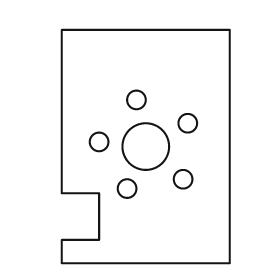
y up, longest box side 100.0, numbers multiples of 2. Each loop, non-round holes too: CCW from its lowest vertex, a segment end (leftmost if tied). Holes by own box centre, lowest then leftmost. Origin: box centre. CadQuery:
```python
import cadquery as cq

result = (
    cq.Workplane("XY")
    .moveTo(-36.0, -50.0)
    .lineTo(36.0, -50.0)
    .lineTo(36.0, 50.0)
    .lineTo(-36.0, 50.0)
    .lineTo(-36.0, -20.0)
    .lineTo(-20.0, -20.0)
    .lineTo(-20.0, -40.0)
    .lineTo(-36.0, -40.0)
    .close()
    .moveTo(-8.0, -18.0)
    .circle(4.0)
    .moveTo(16.0, -14.0)
    .circle(4.0)
    .moveTo(0.0, 0.0)
    .circle(10.0)
    .moveTo(-20.0, 2.0)
    .circle(4.0)
    .moveTo(18.0, 10.0)
    .circle(4.0)
    .moveTo(-4.0, 20.0)
    .circle(4.0)
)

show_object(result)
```